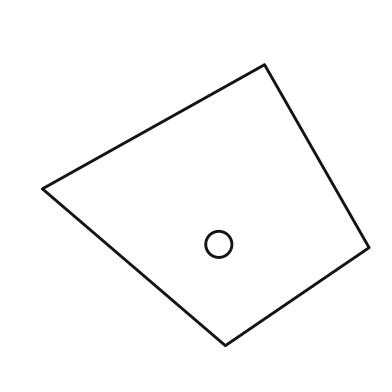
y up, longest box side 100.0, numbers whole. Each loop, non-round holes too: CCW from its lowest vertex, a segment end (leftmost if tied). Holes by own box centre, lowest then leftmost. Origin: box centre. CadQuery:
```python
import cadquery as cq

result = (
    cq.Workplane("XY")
    .moveTo(6.0, -43.0)
    .lineTo(50.0, -13.0)
    .lineTo(18.0, 43.0)
    .lineTo(-50.0, 5.0)
    .close()
    .moveTo(4.0, -12.0)
    .circle(4.0)
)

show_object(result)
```